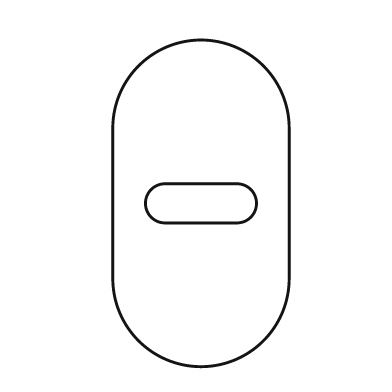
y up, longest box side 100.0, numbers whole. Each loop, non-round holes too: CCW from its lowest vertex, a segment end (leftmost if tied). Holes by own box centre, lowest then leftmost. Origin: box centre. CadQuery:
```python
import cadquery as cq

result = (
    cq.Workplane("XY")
    .moveTo(-27.0, -23.0)
    .threePointArc((0.0, -50.0), (27.0, -23.0))
    .lineTo(27.0, 23.0)
    .threePointArc((0.0, 50.0), (-27.0, 23.0))
    .close()
    .moveTo(-11.0, -6.0)
    .lineTo(11.0, -6.0)
    .threePointArc((17.0, 0.0), (11.0, 6.0))
    .lineTo(-11.0, 6.0)
    .threePointArc((-17.0, 0.0), (-11.0, -6.0))
    .close()
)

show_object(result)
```